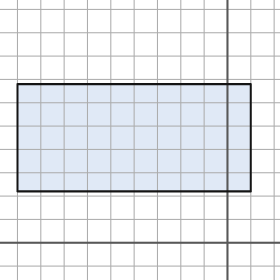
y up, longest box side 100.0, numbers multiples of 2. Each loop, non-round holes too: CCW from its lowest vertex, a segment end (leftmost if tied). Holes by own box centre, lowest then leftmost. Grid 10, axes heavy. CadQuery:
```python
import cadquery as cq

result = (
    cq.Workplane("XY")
    .moveTo(-90.0, 22.0)
    .lineTo(10.0, 22.0)
    .lineTo(10.0, 68.0)
    .lineTo(-90.0, 68.0)
    .close()
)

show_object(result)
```